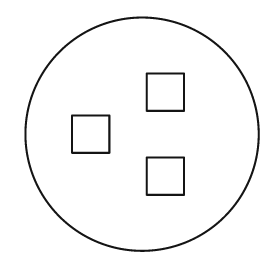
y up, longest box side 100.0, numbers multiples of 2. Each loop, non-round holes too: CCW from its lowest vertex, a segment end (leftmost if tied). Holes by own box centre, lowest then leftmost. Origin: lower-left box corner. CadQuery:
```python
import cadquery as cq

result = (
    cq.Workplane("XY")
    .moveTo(50.0, 50.0)
    .circle(50.0)
    .moveTo(52.0, 24.0)
    .lineTo(68.0, 24.0)
    .lineTo(68.0, 40.0)
    .lineTo(52.0, 40.0)
    .close()
    .moveTo(20.0, 42.0)
    .lineTo(36.0, 42.0)
    .lineTo(36.0, 58.0)
    .lineTo(20.0, 58.0)
    .close()
    .moveTo(52.0, 60.0)
    .lineTo(68.0, 60.0)
    .lineTo(68.0, 76.0)
    .lineTo(52.0, 76.0)
    .close()
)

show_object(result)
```